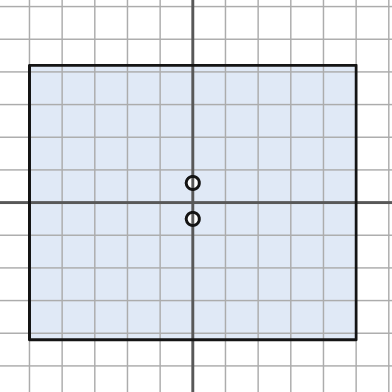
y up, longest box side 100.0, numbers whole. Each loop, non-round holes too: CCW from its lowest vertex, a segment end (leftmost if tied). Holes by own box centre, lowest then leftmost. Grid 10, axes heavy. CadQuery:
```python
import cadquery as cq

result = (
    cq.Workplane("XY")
    .moveTo(-50.0, -42.0)
    .lineTo(50.0, -42.0)
    .lineTo(50.0, 42.0)
    .lineTo(-50.0, 42.0)
    .close()
    .moveTo(0.0, -5.0)
    .circle(2.0)
    .moveTo(0.0, 6.0)
    .circle(2.0)
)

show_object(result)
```